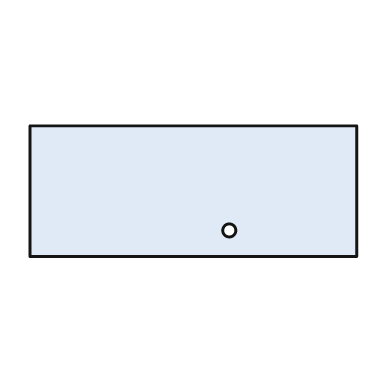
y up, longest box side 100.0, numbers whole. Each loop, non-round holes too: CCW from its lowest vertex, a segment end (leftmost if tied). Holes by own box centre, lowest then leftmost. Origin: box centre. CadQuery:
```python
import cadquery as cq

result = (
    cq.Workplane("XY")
    .moveTo(-50.0, -20.0)
    .lineTo(50.0, -20.0)
    .lineTo(50.0, 20.0)
    .lineTo(-50.0, 20.0)
    .close()
    .moveTo(11.0, -12.0)
    .circle(2.0)
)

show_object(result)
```